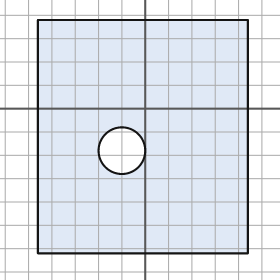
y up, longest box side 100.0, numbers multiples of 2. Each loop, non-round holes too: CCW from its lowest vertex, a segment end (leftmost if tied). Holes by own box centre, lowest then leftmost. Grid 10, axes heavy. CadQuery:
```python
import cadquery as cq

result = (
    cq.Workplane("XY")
    .moveTo(-46.0, -62.0)
    .lineTo(44.0, -62.0)
    .lineTo(44.0, 38.0)
    .lineTo(-46.0, 38.0)
    .close()
    .moveTo(-10.0, -18.0)
    .circle(10.0)
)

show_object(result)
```